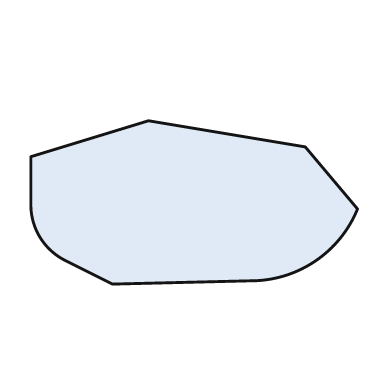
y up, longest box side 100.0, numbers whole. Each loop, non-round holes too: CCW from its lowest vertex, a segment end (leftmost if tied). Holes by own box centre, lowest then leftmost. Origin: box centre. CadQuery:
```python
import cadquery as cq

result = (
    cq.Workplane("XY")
    .moveTo(-25.0, -25.0)
    .lineTo(17.0, -24.0)
    .threePointArc((37.0, -18.0), (50.0, -2.0))
    .lineTo(34.0, 17.0)
    .lineTo(-14.0, 25.0)
    .lineTo(-50.0, 14.0)
    .lineTo(-50.0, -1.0)
    .threePointArc((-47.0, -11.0), (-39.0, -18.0))
    .close()
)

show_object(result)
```